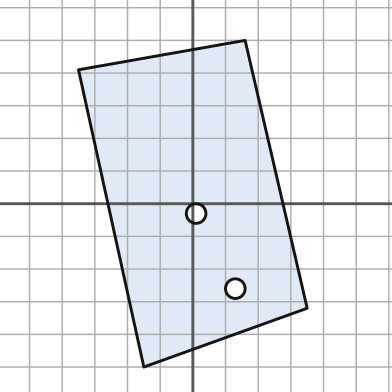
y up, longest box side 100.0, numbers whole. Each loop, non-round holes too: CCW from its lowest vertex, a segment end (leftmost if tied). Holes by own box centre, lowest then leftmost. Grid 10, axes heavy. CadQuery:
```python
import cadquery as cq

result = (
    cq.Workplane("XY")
    .moveTo(-15.0, -50.0)
    .lineTo(35.0, -32.0)
    .lineTo(16.0, 50.0)
    .lineTo(-35.0, 41.0)
    .close()
    .moveTo(13.0, -26.0)
    .circle(3.0)
    .moveTo(1.0, -3.0)
    .circle(3.0)
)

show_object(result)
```